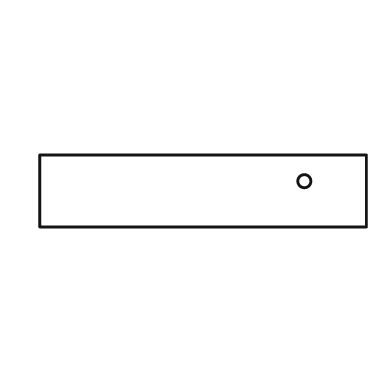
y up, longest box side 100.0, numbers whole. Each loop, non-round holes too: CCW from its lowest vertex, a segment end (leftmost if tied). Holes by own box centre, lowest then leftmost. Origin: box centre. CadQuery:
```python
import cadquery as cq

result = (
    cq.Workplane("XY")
    .moveTo(-50.0, -11.0)
    .lineTo(50.0, -11.0)
    .lineTo(50.0, 11.0)
    .lineTo(-50.0, 11.0)
    .close()
    .moveTo(31.0, 3.0)
    .circle(2.0)
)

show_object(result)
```